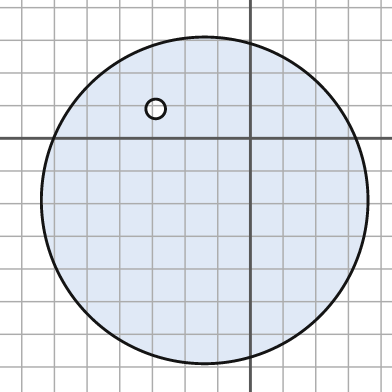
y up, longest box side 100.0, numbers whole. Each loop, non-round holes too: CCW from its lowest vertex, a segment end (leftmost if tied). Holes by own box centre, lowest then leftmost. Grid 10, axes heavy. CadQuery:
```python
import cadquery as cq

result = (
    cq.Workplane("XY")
    .moveTo(-14.0, -19.0)
    .circle(50.0)
    .moveTo(-29.0, 9.0)
    .circle(3.0)
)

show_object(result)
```